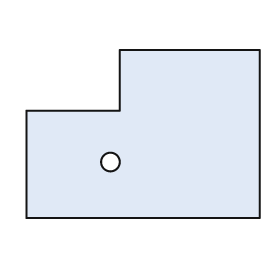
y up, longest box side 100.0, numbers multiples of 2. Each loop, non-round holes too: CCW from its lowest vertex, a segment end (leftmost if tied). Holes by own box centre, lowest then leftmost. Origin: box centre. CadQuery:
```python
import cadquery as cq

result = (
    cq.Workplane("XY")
    .moveTo(-50.0, -36.0)
    .lineTo(50.0, -36.0)
    .lineTo(50.0, 36.0)
    .lineTo(-10.0, 36.0)
    .lineTo(-10.0, 10.0)
    .lineTo(-50.0, 10.0)
    .close()
    .moveTo(-14.0, -12.0)
    .circle(4.0)
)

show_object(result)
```